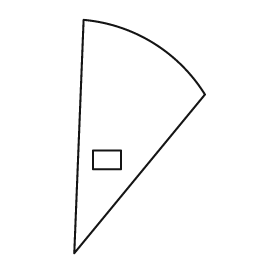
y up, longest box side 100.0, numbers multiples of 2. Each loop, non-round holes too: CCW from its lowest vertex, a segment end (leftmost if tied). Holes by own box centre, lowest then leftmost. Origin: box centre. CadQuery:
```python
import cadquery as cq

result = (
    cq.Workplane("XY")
    .moveTo(-28.0, -50.0)
    .lineTo(28.0, 18.0)
    .threePointArc((6.0, 40.0), (-24.0, 50.0))
    .close()
    .moveTo(-20.0, -14.0)
    .lineTo(-8.0, -14.0)
    .lineTo(-8.0, -6.0)
    .lineTo(-20.0, -6.0)
    .close()
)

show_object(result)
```